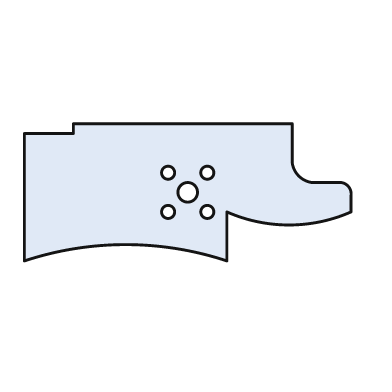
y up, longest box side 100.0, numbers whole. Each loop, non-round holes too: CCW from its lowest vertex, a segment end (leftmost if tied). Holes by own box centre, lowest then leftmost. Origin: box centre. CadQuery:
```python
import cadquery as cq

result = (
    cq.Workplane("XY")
    .moveTo(-50.0, -21.0)
    .threePointArc((-19.0, -16.0), (12.0, -21.0))
    .lineTo(12.0, -6.0)
    .threePointArc((31.0, -10.0), (50.0, -6.0))
    .lineTo(50.0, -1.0)
    .threePointArc((49.0, 2.0), (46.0, 3.0))
    .lineTo(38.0, 3.0)
    .threePointArc((34.0, 5.0), (32.0, 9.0))
    .lineTo(32.0, 21.0)
    .lineTo(-35.0, 21.0)
    .lineTo(-35.0, 18.0)
    .lineTo(-50.0, 18.0)
    .close()
    .moveTo(-6.0, -6.0)
    .circle(2.0)
    .moveTo(6.0, -6.0)
    .circle(2.0)
    .moveTo(0.0, 0.0)
    .circle(3.0)
    .moveTo(-6.0, 6.0)
    .circle(2.0)
    .moveTo(6.0, 6.0)
    .circle(2.0)
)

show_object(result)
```